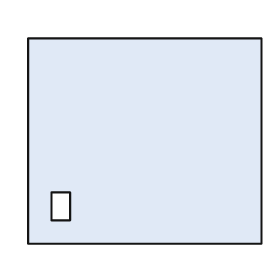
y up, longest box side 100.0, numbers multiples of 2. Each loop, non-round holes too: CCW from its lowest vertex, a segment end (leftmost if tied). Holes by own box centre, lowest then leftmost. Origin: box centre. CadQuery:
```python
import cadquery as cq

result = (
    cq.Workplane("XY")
    .moveTo(-50.0, -44.0)
    .lineTo(50.0, -44.0)
    .lineTo(50.0, 44.0)
    .lineTo(-50.0, 44.0)
    .close()
    .moveTo(-40.0, -34.0)
    .lineTo(-32.0, -34.0)
    .lineTo(-32.0, -22.0)
    .lineTo(-40.0, -22.0)
    .close()
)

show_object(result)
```